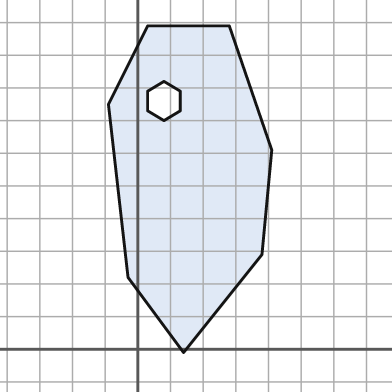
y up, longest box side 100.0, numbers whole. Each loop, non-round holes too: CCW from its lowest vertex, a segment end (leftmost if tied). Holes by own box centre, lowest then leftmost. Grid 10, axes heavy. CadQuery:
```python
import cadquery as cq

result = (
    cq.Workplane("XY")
    .moveTo(14.0, -1.0)
    .lineTo(38.0, 29.0)
    .lineTo(41.0, 61.0)
    .lineTo(28.0, 99.0)
    .lineTo(3.0, 99.0)
    .lineTo(-9.0, 75.0)
    .lineTo(-3.0, 22.0)
    .close()
    .moveTo(8.0, 70.0)
    .lineTo(13.0, 73.0)
    .lineTo(13.0, 79.0)
    .lineTo(8.0, 82.0)
    .lineTo(3.0, 79.0)
    .lineTo(3.0, 73.0)
    .close()
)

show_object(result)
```